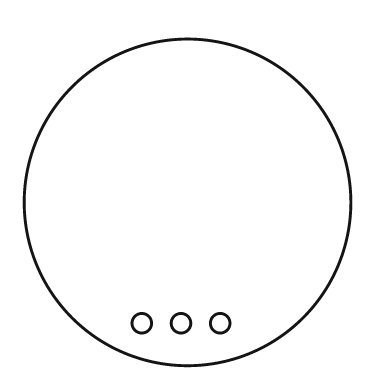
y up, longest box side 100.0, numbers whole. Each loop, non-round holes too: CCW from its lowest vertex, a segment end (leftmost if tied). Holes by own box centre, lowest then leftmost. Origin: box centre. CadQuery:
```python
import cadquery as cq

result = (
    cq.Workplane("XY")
    .moveTo(0.0, 0.0)
    .circle(50.0)
    .moveTo(-14.0, -37.0)
    .circle(3.0)
    .moveTo(-2.0, -37.0)
    .circle(3.0)
    .moveTo(10.0, -37.0)
    .circle(3.0)
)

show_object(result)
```